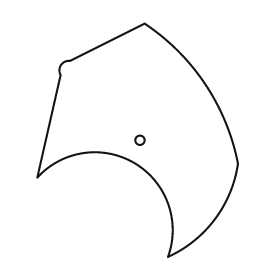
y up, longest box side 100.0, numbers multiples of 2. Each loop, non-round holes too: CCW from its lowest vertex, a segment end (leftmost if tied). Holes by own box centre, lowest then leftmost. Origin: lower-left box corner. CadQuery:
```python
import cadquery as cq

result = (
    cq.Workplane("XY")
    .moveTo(56.0, 0.0)
    .threePointArc((76.0, 16.0), (86.0, 40.0))
    .threePointArc((72.0, 74.0), (46.0, 100.0))
    .lineTo(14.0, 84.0)
    .threePointArc((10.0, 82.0), (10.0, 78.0))
    .lineTo(0.0, 34.0)
    .threePointArc((42.0, 40.0), (56.0, 0.0))
    .close()
    .moveTo(44.0, 50.0)
    .circle(2.0)
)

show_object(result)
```